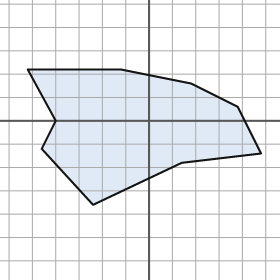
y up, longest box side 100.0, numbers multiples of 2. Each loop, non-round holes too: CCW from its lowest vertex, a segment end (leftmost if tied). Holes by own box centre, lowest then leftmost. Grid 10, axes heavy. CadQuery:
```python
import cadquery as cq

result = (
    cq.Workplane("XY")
    .moveTo(-24.0, -36.0)
    .lineTo(14.0, -18.0)
    .lineTo(48.0, -14.0)
    .lineTo(38.0, 6.0)
    .lineTo(18.0, 16.0)
    .lineTo(-12.0, 22.0)
    .lineTo(-52.0, 22.0)
    .lineTo(-40.0, 0.0)
    .lineTo(-46.0, -12.0)
    .close()
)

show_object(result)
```